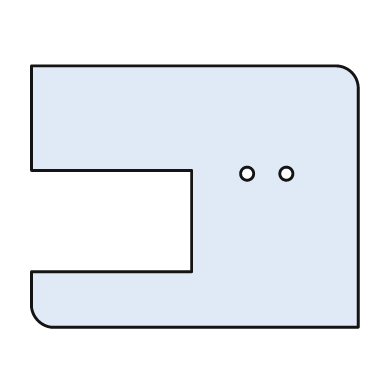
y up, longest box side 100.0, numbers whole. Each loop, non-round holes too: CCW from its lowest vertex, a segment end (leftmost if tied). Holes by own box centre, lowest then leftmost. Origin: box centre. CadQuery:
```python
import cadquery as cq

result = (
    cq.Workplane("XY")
    .moveTo(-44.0, -40.0)
    .lineTo(50.0, -40.0)
    .lineTo(50.0, 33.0)
    .threePointArc((48.0, 38.0), (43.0, 40.0))
    .lineTo(-50.0, 40.0)
    .lineTo(-50.0, 8.0)
    .lineTo(-1.0, 8.0)
    .lineTo(-1.0, -23.0)
    .lineTo(-50.0, -23.0)
    .lineTo(-50.0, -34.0)
    .threePointArc((-48.0, -38.0), (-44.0, -40.0))
    .close()
    .moveTo(16.0, 7.0)
    .circle(2.0)
    .moveTo(28.0, 7.0)
    .circle(2.0)
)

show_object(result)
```